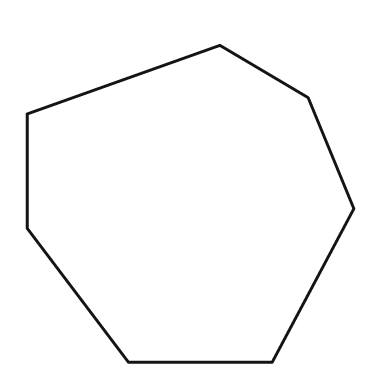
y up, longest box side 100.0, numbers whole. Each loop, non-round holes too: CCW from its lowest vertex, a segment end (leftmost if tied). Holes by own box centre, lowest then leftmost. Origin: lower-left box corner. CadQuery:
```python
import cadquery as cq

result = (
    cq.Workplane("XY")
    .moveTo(31.0, 0.0)
    .lineTo(75.0, 0.0)
    .lineTo(100.0, 47.0)
    .lineTo(86.0, 81.0)
    .lineTo(59.0, 97.0)
    .lineTo(0.0, 76.0)
    .lineTo(0.0, 41.0)
    .close()
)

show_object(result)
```